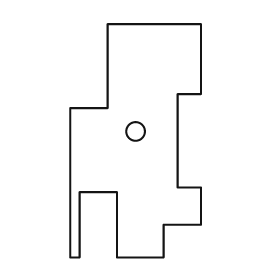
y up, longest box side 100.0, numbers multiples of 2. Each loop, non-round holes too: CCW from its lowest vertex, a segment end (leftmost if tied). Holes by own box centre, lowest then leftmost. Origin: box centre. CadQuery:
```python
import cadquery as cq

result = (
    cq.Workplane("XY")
    .moveTo(-28.0, -50.0)
    .lineTo(-24.0, -50.0)
    .lineTo(-24.0, -22.0)
    .lineTo(-8.0, -22.0)
    .lineTo(-8.0, -50.0)
    .lineTo(12.0, -50.0)
    .lineTo(12.0, -36.0)
    .lineTo(28.0, -36.0)
    .lineTo(28.0, -20.0)
    .lineTo(18.0, -20.0)
    .lineTo(18.0, 20.0)
    .lineTo(28.0, 20.0)
    .lineTo(28.0, 50.0)
    .lineTo(-12.0, 50.0)
    .lineTo(-12.0, 14.0)
    .lineTo(-28.0, 14.0)
    .close()
    .moveTo(0.0, 4.0)
    .circle(4.0)
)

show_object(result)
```